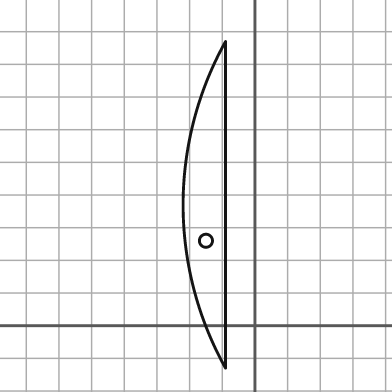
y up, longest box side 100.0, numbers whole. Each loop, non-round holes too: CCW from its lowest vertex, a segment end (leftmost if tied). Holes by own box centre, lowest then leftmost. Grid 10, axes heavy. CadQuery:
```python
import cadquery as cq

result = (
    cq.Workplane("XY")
    .moveTo(-9.0, -13.0)
    .lineTo(-9.0, 87.0)
    .threePointArc((-22.0, 37.0), (-9.0, -13.0))
    .close()
    .moveTo(-15.0, 26.0)
    .circle(2.0)
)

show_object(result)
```